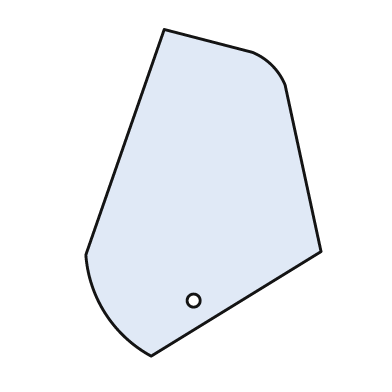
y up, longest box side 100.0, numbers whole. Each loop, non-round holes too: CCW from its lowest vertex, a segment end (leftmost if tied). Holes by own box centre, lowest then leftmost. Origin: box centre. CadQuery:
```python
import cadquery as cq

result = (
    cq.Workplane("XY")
    .moveTo(-16.0, -50.0)
    .lineTo(36.0, -18.0)
    .lineTo(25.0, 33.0)
    .threePointArc((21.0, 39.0), (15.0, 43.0))
    .lineTo(-12.0, 50.0)
    .lineTo(-36.0, -19.0)
    .threePointArc((-30.0, -37.0), (-16.0, -50.0))
    .close()
    .moveTo(-3.0, -33.0)
    .circle(2.0)
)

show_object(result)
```